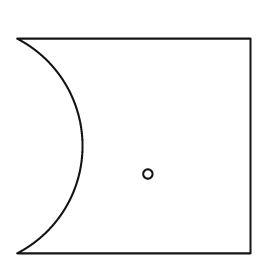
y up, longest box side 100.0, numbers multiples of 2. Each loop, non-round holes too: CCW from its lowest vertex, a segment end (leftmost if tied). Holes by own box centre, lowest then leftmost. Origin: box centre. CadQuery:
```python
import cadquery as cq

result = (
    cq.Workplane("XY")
    .moveTo(-50.0, -46.0)
    .lineTo(50.0, -46.0)
    .lineTo(50.0, 46.0)
    .lineTo(-50.0, 46.0)
    .threePointArc((-22.0, 0.0), (-50.0, -46.0))
    .close()
    .moveTo(6.0, -12.0)
    .circle(2.0)
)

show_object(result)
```